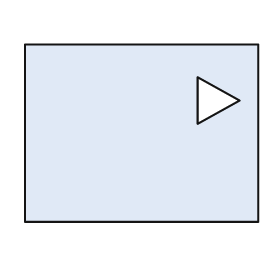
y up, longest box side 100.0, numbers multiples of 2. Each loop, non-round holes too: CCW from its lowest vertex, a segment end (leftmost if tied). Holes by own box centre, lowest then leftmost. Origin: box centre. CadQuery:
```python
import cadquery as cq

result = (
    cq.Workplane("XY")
    .moveTo(-50.0, -38.0)
    .lineTo(50.0, -38.0)
    .lineTo(50.0, 38.0)
    .lineTo(-50.0, 38.0)
    .close()
    .moveTo(24.0, 4.0)
    .lineTo(42.0, 14.0)
    .lineTo(24.0, 24.0)
    .close()
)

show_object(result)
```